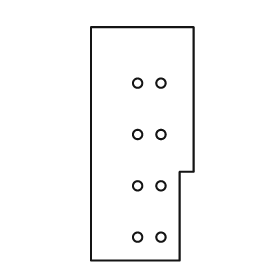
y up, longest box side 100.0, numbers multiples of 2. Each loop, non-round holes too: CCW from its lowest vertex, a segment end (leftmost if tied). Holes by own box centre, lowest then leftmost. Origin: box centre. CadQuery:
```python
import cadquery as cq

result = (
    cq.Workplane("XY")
    .moveTo(-22.0, -50.0)
    .lineTo(16.0, -50.0)
    .lineTo(16.0, -12.0)
    .lineTo(22.0, -12.0)
    .lineTo(22.0, 50.0)
    .lineTo(-22.0, 50.0)
    .close()
    .moveTo(-2.0, -40.0)
    .circle(2.0)
    .moveTo(8.0, -40.0)
    .circle(2.0)
    .moveTo(-2.0, -18.0)
    .circle(2.0)
    .moveTo(8.0, -18.0)
    .circle(2.0)
    .moveTo(-2.0, 4.0)
    .circle(2.0)
    .moveTo(8.0, 4.0)
    .circle(2.0)
    .moveTo(-2.0, 26.0)
    .circle(2.0)
    .moveTo(8.0, 26.0)
    .circle(2.0)
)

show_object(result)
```